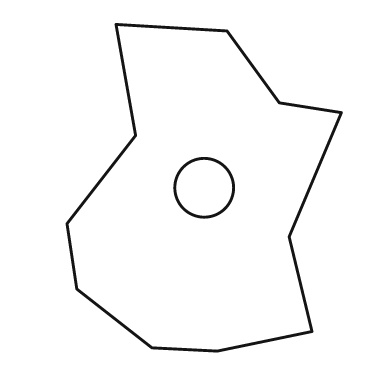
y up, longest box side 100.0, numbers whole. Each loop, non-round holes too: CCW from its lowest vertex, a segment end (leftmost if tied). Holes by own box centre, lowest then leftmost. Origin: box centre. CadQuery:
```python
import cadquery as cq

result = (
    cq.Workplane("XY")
    .moveTo(4.0, -50.0)
    .lineTo(33.0, -44.0)
    .lineTo(26.0, -15.0)
    .lineTo(42.0, 23.0)
    .lineTo(23.0, 26.0)
    .lineTo(7.0, 48.0)
    .lineTo(-27.0, 50.0)
    .lineTo(-21.0, 16.0)
    .lineTo(-42.0, -11.0)
    .lineTo(-39.0, -31.0)
    .lineTo(-16.0, -49.0)
    .close()
    .moveTo(0.0, 0.0)
    .circle(9.0)
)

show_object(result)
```